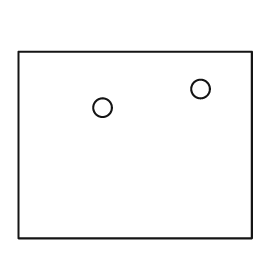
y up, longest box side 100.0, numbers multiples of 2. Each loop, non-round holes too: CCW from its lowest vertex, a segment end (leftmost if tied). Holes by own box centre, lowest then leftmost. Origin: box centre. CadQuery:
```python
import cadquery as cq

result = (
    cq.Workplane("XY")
    .moveTo(-50.0, -40.0)
    .lineTo(50.0, -40.0)
    .lineTo(50.0, 40.0)
    .lineTo(-50.0, 40.0)
    .close()
    .moveTo(-14.0, 16.0)
    .circle(4.0)
    .moveTo(28.0, 24.0)
    .circle(4.0)
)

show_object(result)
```